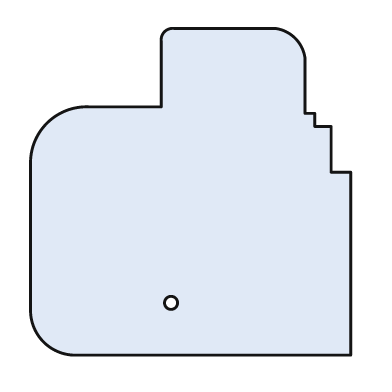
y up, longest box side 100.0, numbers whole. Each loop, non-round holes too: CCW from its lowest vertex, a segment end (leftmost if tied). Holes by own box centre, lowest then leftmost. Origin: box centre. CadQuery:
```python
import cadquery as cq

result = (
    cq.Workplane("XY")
    .moveTo(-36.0, -50.0)
    .lineTo(49.0, -50.0)
    .lineTo(49.0, 6.0)
    .lineTo(43.0, 6.0)
    .lineTo(43.0, 20.0)
    .lineTo(38.0, 20.0)
    .lineTo(38.0, 24.0)
    .lineTo(35.0, 24.0)
    .lineTo(35.0, 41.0)
    .threePointArc((32.0, 47.0), (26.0, 50.0))
    .lineTo(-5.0, 50.0)
    .threePointArc((-8.0, 49.0), (-9.0, 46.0))
    .lineTo(-9.0, 26.0)
    .lineTo(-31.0, 26.0)
    .threePointArc((-44.0, 21.0), (-49.0, 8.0))
    .lineTo(-49.0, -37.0)
    .threePointArc((-45.0, -46.0), (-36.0, -50.0))
    .close()
    .moveTo(-6.0, -34.0)
    .circle(2.0)
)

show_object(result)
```